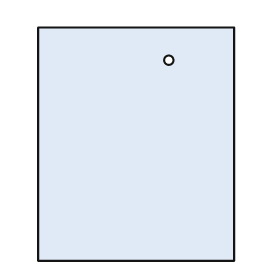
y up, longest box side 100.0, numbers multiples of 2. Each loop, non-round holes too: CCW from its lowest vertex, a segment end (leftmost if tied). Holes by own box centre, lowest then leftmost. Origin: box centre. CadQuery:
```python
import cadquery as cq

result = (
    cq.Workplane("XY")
    .moveTo(-42.0, -50.0)
    .lineTo(42.0, -50.0)
    .lineTo(42.0, 50.0)
    .lineTo(-42.0, 50.0)
    .close()
    .moveTo(14.0, 36.0)
    .circle(2.0)
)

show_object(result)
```